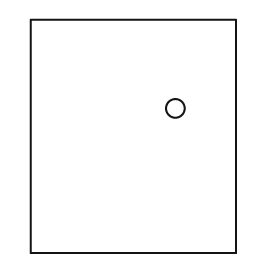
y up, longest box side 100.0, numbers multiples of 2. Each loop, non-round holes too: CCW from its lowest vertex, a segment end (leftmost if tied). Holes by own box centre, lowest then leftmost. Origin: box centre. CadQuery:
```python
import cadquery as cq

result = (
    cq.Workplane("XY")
    .moveTo(-44.0, -50.0)
    .lineTo(44.0, -50.0)
    .lineTo(44.0, 50.0)
    .lineTo(-44.0, 50.0)
    .close()
    .moveTo(18.0, 12.0)
    .circle(4.0)
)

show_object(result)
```